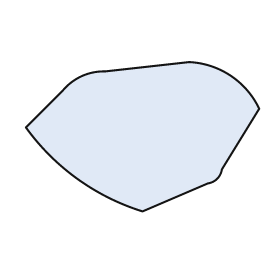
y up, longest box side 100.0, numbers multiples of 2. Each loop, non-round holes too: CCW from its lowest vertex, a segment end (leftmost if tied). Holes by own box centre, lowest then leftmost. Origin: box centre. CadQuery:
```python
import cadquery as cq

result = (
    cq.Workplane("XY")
    .moveTo(0.0, -32.0)
    .lineTo(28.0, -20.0)
    .threePointArc((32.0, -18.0), (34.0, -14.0))
    .lineTo(50.0, 12.0)
    .threePointArc((38.0, 26.0), (20.0, 32.0))
    .lineTo(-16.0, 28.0)
    .threePointArc((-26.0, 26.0), (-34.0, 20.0))
    .lineTo(-50.0, 4.0)
    .threePointArc((-28.0, -18.0), (0.0, -32.0))
    .close()
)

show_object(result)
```